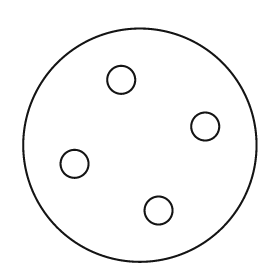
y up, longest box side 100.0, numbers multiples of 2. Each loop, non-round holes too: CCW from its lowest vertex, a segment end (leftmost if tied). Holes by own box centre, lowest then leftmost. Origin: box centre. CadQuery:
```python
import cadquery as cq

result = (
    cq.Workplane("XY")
    .moveTo(0.0, 0.0)
    .circle(50.0)
    .moveTo(8.0, -28.0)
    .circle(6.0)
    .moveTo(-28.0, -8.0)
    .circle(6.0)
    .moveTo(28.0, 8.0)
    .circle(6.0)
    .moveTo(-8.0, 28.0)
    .circle(6.0)
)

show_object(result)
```